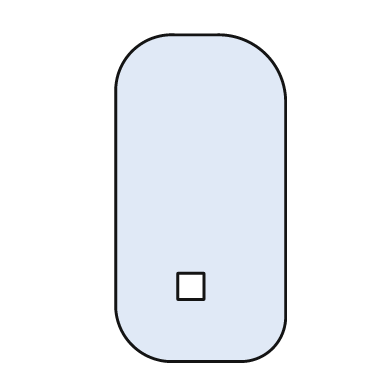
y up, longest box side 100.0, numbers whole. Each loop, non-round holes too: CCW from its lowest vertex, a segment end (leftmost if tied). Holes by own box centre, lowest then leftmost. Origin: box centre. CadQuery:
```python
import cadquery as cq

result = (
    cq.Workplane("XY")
    .moveTo(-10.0, -50.0)
    .lineTo(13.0, -50.0)
    .threePointArc((22.0, -46.0), (26.0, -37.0))
    .lineTo(26.0, 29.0)
    .threePointArc((20.0, 44.0), (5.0, 50.0))
    .lineTo(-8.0, 50.0)
    .threePointArc((-21.0, 45.0), (-26.0, 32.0))
    .lineTo(-26.0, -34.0)
    .threePointArc((-21.0, -45.0), (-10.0, -50.0))
    .close()
    .moveTo(-7.0, -31.0)
    .lineTo(1.0, -31.0)
    .lineTo(1.0, -23.0)
    .lineTo(-7.0, -23.0)
    .close()
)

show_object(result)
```